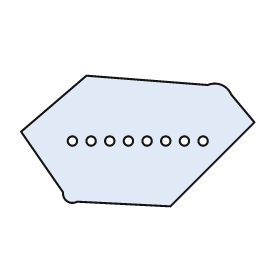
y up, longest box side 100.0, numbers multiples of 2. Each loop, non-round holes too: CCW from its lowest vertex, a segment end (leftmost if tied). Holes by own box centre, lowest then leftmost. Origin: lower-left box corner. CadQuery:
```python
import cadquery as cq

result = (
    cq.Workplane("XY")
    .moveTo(64.0, 0.0)
    .lineTo(100.0, 36.0)
    .lineTo(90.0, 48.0)
    .threePointArc((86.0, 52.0), (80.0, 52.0))
    .lineTo(28.0, 56.0)
    .lineTo(0.0, 32.0)
    .lineTo(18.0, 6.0)
    .threePointArc((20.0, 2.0), (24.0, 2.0))
    .close()
    .moveTo(22.0, 28.0)
    .circle(2.0)
    .moveTo(30.0, 28.0)
    .circle(2.0)
    .moveTo(38.0, 28.0)
    .circle(2.0)
    .moveTo(46.0, 28.0)
    .circle(2.0)
    .moveTo(54.0, 28.0)
    .circle(2.0)
    .moveTo(62.0, 28.0)
    .circle(2.0)
    .moveTo(70.0, 28.0)
    .circle(2.0)
    .moveTo(78.0, 28.0)
    .circle(2.0)
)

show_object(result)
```